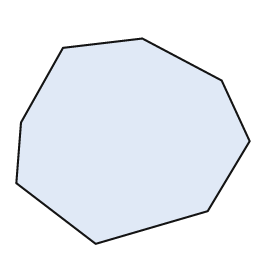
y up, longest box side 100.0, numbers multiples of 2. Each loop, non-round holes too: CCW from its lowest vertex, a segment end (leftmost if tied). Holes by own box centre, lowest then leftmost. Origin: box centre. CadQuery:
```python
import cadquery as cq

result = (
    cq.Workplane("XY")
    .moveTo(-16.0, -44.0)
    .lineTo(32.0, -30.0)
    .lineTo(50.0, 0.0)
    .lineTo(38.0, 26.0)
    .lineTo(4.0, 44.0)
    .lineTo(-30.0, 40.0)
    .lineTo(-48.0, 8.0)
    .lineTo(-50.0, -18.0)
    .close()
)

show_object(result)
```